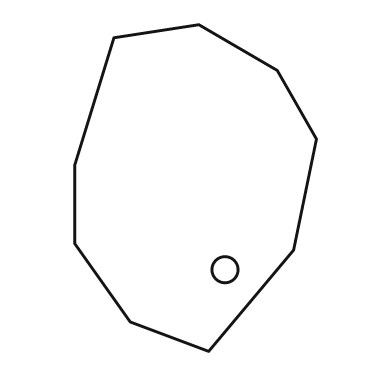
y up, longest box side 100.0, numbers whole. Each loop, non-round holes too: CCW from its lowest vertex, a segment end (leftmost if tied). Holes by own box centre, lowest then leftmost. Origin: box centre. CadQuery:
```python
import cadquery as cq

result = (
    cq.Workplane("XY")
    .moveTo(4.0, -50.0)
    .lineTo(30.0, -19.0)
    .lineTo(37.0, 15.0)
    .lineTo(25.0, 36.0)
    .lineTo(1.0, 50.0)
    .lineTo(-25.0, 46.0)
    .lineTo(-37.0, 7.0)
    .lineTo(-37.0, -17.0)
    .lineTo(-20.0, -41.0)
    .close()
    .moveTo(9.0, -25.0)
    .circle(4.0)
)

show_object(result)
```